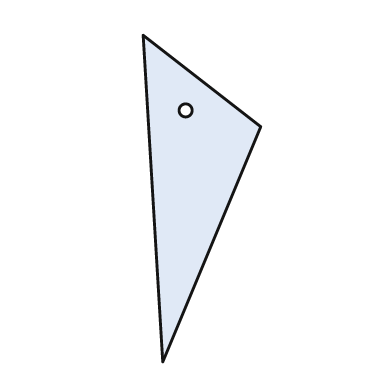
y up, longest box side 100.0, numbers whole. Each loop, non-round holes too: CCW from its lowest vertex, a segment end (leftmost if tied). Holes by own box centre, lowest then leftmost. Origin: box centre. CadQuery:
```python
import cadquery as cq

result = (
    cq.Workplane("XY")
    .moveTo(-12.0, -50.0)
    .lineTo(18.0, 22.0)
    .lineTo(-18.0, 50.0)
    .close()
    .moveTo(-5.0, 27.0)
    .circle(2.0)
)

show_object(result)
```